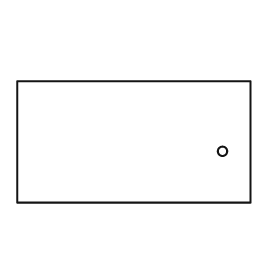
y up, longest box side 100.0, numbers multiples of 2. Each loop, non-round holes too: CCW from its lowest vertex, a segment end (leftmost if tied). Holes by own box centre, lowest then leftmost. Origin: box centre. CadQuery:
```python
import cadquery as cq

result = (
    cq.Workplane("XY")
    .moveTo(-50.0, -26.0)
    .lineTo(50.0, -26.0)
    .lineTo(50.0, 26.0)
    .lineTo(-50.0, 26.0)
    .close()
    .moveTo(38.0, -4.0)
    .circle(2.0)
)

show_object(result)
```